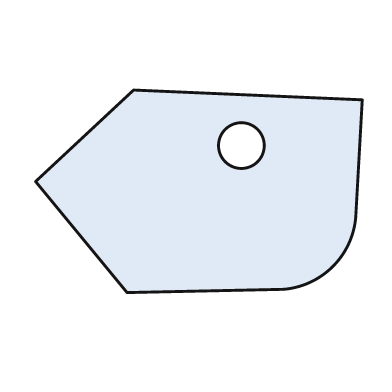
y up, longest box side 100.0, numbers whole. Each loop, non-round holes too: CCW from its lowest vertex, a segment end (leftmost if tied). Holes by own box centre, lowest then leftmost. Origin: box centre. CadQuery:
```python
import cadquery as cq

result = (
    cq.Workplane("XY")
    .moveTo(-22.0, -31.0)
    .lineTo(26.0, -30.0)
    .threePointArc((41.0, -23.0), (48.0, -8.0))
    .lineTo(50.0, 28.0)
    .lineTo(-20.0, 31.0)
    .lineTo(-50.0, 3.0)
    .close()
    .moveTo(13.0, 14.0)
    .circle(7.0)
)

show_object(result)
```